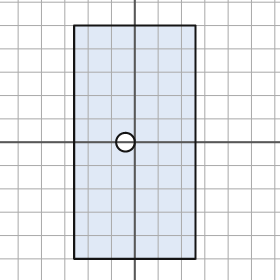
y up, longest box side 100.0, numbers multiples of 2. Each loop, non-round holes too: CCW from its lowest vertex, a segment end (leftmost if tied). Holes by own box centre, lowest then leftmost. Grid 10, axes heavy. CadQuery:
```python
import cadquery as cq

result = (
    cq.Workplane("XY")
    .moveTo(-26.0, -50.0)
    .lineTo(26.0, -50.0)
    .lineTo(26.0, 50.0)
    .lineTo(-26.0, 50.0)
    .close()
    .moveTo(-4.0, 0.0)
    .circle(4.0)
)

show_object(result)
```